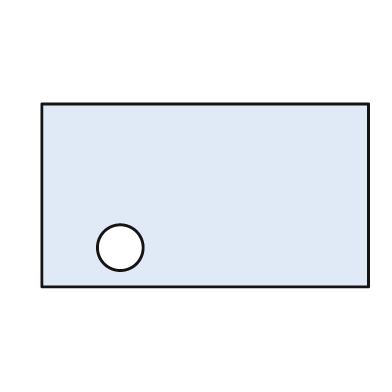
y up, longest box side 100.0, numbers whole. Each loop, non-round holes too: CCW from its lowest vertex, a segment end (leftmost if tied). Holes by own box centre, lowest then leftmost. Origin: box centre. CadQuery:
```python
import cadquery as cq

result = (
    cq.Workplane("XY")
    .moveTo(-50.0, -28.0)
    .lineTo(50.0, -28.0)
    .lineTo(50.0, 28.0)
    .lineTo(-50.0, 28.0)
    .close()
    .moveTo(-26.0, -16.0)
    .circle(7.0)
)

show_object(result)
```